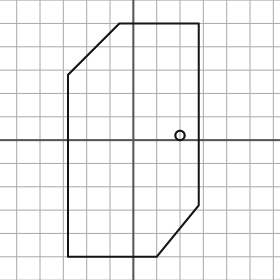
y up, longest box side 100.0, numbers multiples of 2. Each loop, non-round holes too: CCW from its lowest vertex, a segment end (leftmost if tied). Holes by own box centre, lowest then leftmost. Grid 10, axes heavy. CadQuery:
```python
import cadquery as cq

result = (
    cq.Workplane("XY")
    .moveTo(-28.0, -50.0)
    .lineTo(10.0, -50.0)
    .lineTo(28.0, -28.0)
    .lineTo(28.0, 50.0)
    .lineTo(-6.0, 50.0)
    .lineTo(-28.0, 28.0)
    .close()
    .moveTo(20.0, 2.0)
    .circle(2.0)
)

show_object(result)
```